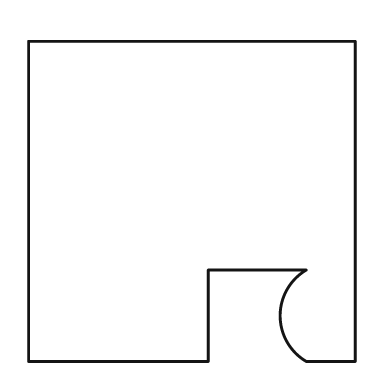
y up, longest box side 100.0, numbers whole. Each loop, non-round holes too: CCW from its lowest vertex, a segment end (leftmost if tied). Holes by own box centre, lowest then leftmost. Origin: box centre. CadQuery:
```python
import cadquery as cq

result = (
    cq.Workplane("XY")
    .moveTo(-50.0, -49.0)
    .lineTo(5.0, -49.0)
    .lineTo(5.0, -21.0)
    .lineTo(35.0, -21.0)
    .threePointArc((27.0, -35.0), (35.0, -49.0))
    .lineTo(50.0, -49.0)
    .lineTo(50.0, 49.0)
    .lineTo(-50.0, 49.0)
    .close()
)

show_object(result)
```